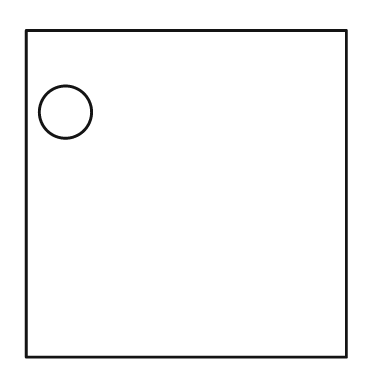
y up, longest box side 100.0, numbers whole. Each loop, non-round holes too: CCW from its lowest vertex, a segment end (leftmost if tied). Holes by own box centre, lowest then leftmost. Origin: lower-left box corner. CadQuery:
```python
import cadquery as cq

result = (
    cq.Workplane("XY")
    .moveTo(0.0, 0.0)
    .lineTo(98.0, 0.0)
    .lineTo(98.0, 100.0)
    .lineTo(0.0, 100.0)
    .close()
    .moveTo(12.0, 75.0)
    .circle(8.0)
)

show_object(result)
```